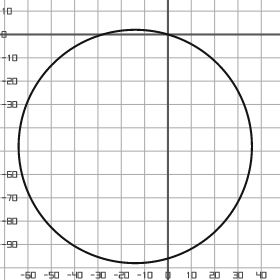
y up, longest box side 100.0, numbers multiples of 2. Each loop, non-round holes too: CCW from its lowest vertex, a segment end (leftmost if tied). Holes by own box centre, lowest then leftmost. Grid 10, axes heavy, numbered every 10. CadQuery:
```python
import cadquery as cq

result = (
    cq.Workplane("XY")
    .moveTo(-14.0, -48.0)
    .circle(50.0)
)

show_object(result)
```